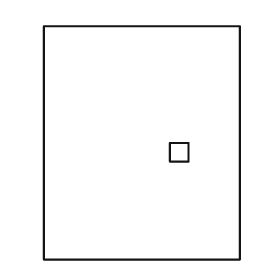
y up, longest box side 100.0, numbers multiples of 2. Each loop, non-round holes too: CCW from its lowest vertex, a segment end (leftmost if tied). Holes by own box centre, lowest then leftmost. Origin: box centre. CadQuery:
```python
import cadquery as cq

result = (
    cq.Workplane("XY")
    .moveTo(-42.0, -50.0)
    .lineTo(42.0, -50.0)
    .lineTo(42.0, 50.0)
    .lineTo(-42.0, 50.0)
    .close()
    .moveTo(12.0, -8.0)
    .lineTo(20.0, -8.0)
    .lineTo(20.0, 0.0)
    .lineTo(12.0, 0.0)
    .close()
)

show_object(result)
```